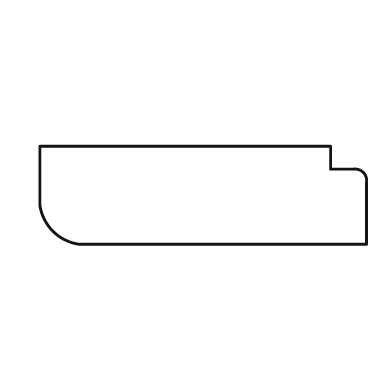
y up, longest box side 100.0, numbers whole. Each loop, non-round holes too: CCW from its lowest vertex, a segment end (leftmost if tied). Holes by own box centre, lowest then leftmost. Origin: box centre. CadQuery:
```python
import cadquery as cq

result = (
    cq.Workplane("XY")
    .moveTo(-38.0, -15.0)
    .lineTo(50.0, -15.0)
    .lineTo(50.0, 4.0)
    .threePointArc((49.0, 7.0), (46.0, 8.0))
    .lineTo(39.0, 8.0)
    .lineTo(39.0, 15.0)
    .lineTo(-50.0, 15.0)
    .lineTo(-50.0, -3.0)
    .threePointArc((-46.0, -11.0), (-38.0, -15.0))
    .close()
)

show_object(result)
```